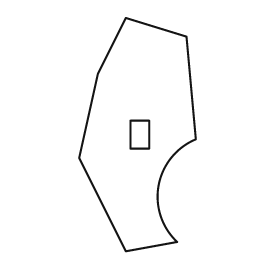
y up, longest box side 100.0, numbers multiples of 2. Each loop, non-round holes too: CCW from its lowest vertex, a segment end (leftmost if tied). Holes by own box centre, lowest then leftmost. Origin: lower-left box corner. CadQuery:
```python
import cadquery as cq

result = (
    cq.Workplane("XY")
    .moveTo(20.0, 0.0)
    .lineTo(42.0, 4.0)
    .threePointArc((34.0, 28.0), (50.0, 48.0))
    .lineTo(46.0, 92.0)
    .lineTo(20.0, 100.0)
    .lineTo(8.0, 76.0)
    .lineTo(0.0, 40.0)
    .close()
    .moveTo(22.0, 44.0)
    .lineTo(30.0, 44.0)
    .lineTo(30.0, 56.0)
    .lineTo(22.0, 56.0)
    .close()
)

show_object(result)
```